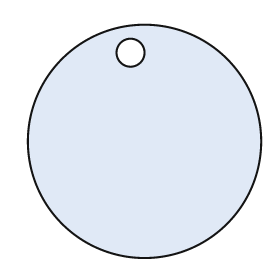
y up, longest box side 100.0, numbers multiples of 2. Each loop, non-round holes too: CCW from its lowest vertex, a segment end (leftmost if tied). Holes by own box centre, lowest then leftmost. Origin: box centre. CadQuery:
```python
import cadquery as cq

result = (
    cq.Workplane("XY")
    .moveTo(0.0, 0.0)
    .circle(50.0)
    .moveTo(-6.0, 38.0)
    .circle(6.0)
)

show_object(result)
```